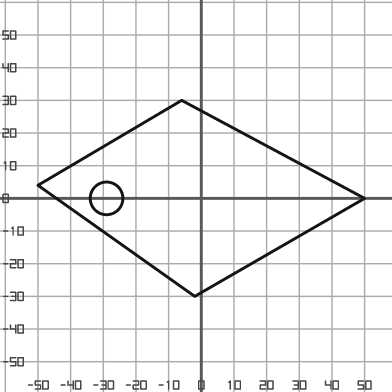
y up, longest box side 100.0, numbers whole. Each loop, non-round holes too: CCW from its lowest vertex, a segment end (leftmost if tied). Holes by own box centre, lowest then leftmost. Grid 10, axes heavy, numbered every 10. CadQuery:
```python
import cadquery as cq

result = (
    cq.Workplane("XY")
    .moveTo(-2.0, -30.0)
    .lineTo(50.0, 0.0)
    .lineTo(-6.0, 30.0)
    .lineTo(-50.0, 4.0)
    .close()
    .moveTo(-29.0, 0.0)
    .circle(5.0)
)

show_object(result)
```